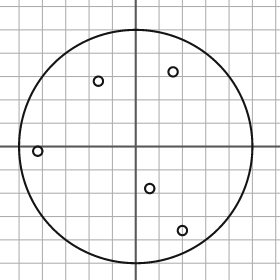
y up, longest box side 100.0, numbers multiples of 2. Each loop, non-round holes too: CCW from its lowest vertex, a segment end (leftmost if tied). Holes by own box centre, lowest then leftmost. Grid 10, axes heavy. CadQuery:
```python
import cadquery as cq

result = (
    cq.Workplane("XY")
    .moveTo(0.0, 0.0)
    .circle(50.0)
    .moveTo(20.0, -36.0)
    .circle(2.0)
    .moveTo(6.0, -18.0)
    .circle(2.0)
    .moveTo(-42.0, -2.0)
    .circle(2.0)
    .moveTo(-16.0, 28.0)
    .circle(2.0)
    .moveTo(16.0, 32.0)
    .circle(2.0)
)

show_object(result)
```